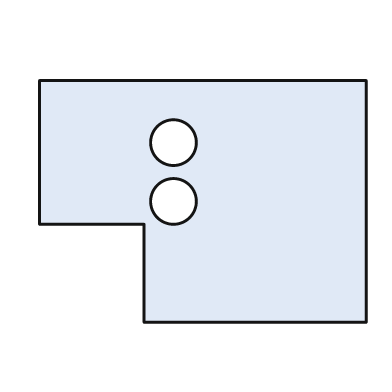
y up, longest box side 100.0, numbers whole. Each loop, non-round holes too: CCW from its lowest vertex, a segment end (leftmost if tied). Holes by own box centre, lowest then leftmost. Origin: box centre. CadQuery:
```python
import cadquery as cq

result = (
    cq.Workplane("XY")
    .moveTo(-18.0, -37.0)
    .lineTo(50.0, -37.0)
    .lineTo(50.0, 37.0)
    .lineTo(-50.0, 37.0)
    .lineTo(-50.0, -7.0)
    .lineTo(-18.0, -7.0)
    .close()
    .moveTo(-9.0, 0.0)
    .circle(7.0)
    .moveTo(-9.0, 18.0)
    .circle(7.0)
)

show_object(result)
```